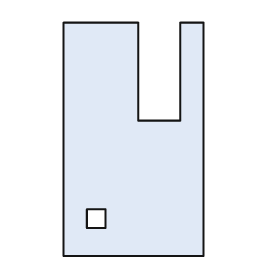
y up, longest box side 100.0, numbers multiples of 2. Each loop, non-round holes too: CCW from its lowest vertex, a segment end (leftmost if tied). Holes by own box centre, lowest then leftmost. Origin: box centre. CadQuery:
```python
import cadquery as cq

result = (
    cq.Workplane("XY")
    .moveTo(-30.0, -50.0)
    .lineTo(30.0, -50.0)
    .lineTo(30.0, 50.0)
    .lineTo(20.0, 50.0)
    .lineTo(20.0, 8.0)
    .lineTo(2.0, 8.0)
    .lineTo(2.0, 50.0)
    .lineTo(-30.0, 50.0)
    .close()
    .moveTo(-20.0, -38.0)
    .lineTo(-12.0, -38.0)
    .lineTo(-12.0, -30.0)
    .lineTo(-20.0, -30.0)
    .close()
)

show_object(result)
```